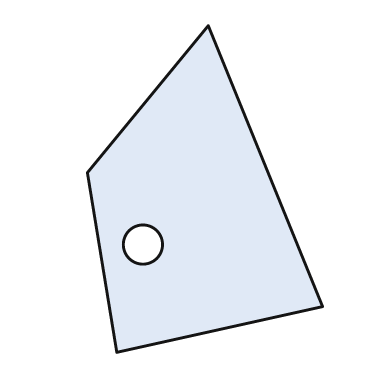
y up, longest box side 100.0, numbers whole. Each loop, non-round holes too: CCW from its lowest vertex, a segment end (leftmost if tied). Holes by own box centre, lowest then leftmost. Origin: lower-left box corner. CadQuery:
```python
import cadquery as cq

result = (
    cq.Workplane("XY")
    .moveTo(9.0, 0.0)
    .lineTo(72.0, 14.0)
    .lineTo(37.0, 100.0)
    .lineTo(0.0, 55.0)
    .close()
    .moveTo(17.0, 33.0)
    .circle(6.0)
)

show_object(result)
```